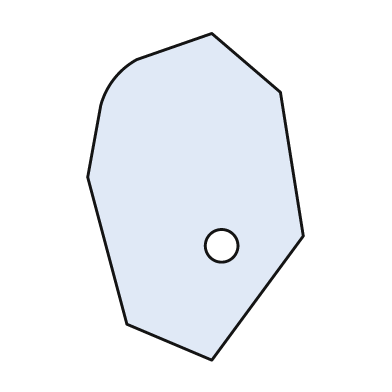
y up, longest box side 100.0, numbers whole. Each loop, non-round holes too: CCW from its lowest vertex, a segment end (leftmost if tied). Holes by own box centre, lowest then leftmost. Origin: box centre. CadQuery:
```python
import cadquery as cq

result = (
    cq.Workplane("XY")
    .moveTo(5.0, -50.0)
    .lineTo(33.0, -12.0)
    .lineTo(26.0, 32.0)
    .lineTo(5.0, 50.0)
    .lineTo(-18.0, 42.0)
    .threePointArc((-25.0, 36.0), (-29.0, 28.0))
    .lineTo(-33.0, 6.0)
    .lineTo(-21.0, -39.0)
    .close()
    .moveTo(8.0, -15.0)
    .circle(5.0)
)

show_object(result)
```